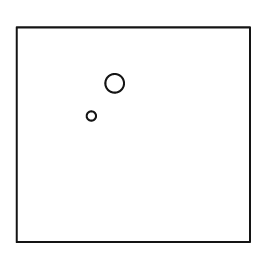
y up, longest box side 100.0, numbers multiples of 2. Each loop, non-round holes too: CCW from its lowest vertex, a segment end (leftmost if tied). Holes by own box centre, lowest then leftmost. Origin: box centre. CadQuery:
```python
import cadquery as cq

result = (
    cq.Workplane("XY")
    .moveTo(-50.0, -46.0)
    .lineTo(50.0, -46.0)
    .lineTo(50.0, 46.0)
    .lineTo(-50.0, 46.0)
    .close()
    .moveTo(-18.0, 8.0)
    .circle(2.0)
    .moveTo(-8.0, 22.0)
    .circle(4.0)
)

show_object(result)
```